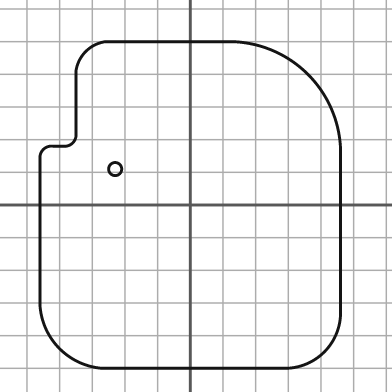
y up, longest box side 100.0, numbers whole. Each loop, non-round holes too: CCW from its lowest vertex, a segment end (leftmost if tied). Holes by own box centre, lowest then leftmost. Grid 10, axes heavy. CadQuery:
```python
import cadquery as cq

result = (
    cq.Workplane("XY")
    .moveTo(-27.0, -50.0)
    .lineTo(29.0, -50.0)
    .threePointArc((41.0, -45.0), (46.0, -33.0))
    .lineTo(46.0, 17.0)
    .threePointArc((36.0, 40.0), (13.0, 50.0))
    .lineTo(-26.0, 50.0)
    .threePointArc((-32.0, 47.0), (-35.0, 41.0))
    .lineTo(-35.0, 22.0)
    .threePointArc((-36.0, 19.0), (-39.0, 18.0))
    .lineTo(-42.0, 18.0)
    .threePointArc((-45.0, 17.0), (-46.0, 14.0))
    .lineTo(-46.0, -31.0)
    .threePointArc((-40.0, -44.0), (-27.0, -50.0))
    .close()
    .moveTo(-23.0, 11.0)
    .circle(2.0)
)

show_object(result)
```